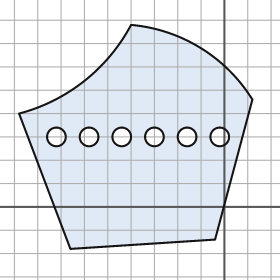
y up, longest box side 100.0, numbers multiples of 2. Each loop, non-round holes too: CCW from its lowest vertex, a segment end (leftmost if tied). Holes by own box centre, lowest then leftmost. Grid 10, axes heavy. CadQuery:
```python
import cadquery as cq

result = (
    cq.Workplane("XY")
    .moveTo(-66.0, -18.0)
    .lineTo(-4.0, -14.0)
    .lineTo(12.0, 46.0)
    .threePointArc((-10.0, 68.0), (-40.0, 78.0))
    .threePointArc((-60.0, 54.0), (-88.0, 40.0))
    .close()
    .moveTo(-72.0, 30.0)
    .circle(4.0)
    .moveTo(-58.0, 30.0)
    .circle(4.0)
    .moveTo(-44.0, 30.0)
    .circle(4.0)
    .moveTo(-30.0, 30.0)
    .circle(4.0)
    .moveTo(-16.0, 30.0)
    .circle(4.0)
    .moveTo(-2.0, 30.0)
    .circle(4.0)
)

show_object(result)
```